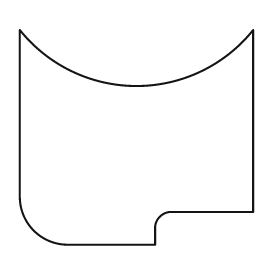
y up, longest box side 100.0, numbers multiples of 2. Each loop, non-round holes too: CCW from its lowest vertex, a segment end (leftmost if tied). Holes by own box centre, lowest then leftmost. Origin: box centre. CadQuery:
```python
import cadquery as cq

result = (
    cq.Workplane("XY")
    .moveTo(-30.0, -46.0)
    .lineTo(8.0, -46.0)
    .lineTo(8.0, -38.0)
    .threePointArc((10.0, -34.0), (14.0, -32.0))
    .lineTo(50.0, -32.0)
    .lineTo(50.0, 46.0)
    .threePointArc((0.0, 22.0), (-50.0, 46.0))
    .lineTo(-50.0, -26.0)
    .threePointArc((-44.0, -40.0), (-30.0, -46.0))
    .close()
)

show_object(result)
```